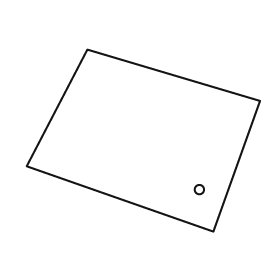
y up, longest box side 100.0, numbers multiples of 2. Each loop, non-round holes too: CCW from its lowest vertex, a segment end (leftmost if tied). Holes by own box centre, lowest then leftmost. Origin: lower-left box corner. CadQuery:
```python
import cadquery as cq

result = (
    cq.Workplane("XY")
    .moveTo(80.0, 0.0)
    .lineTo(100.0, 56.0)
    .lineTo(26.0, 78.0)
    .lineTo(0.0, 28.0)
    .close()
    .moveTo(74.0, 18.0)
    .circle(2.0)
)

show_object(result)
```